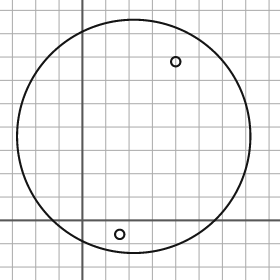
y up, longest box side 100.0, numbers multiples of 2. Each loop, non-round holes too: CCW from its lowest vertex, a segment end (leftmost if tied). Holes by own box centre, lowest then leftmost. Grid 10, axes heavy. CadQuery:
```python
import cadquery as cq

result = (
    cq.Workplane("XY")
    .moveTo(22.0, 36.0)
    .circle(50.0)
    .moveTo(16.0, -6.0)
    .circle(2.0)
    .moveTo(40.0, 68.0)
    .circle(2.0)
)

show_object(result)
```